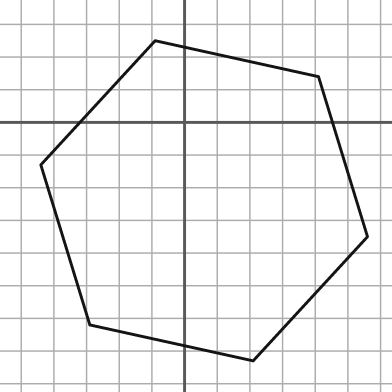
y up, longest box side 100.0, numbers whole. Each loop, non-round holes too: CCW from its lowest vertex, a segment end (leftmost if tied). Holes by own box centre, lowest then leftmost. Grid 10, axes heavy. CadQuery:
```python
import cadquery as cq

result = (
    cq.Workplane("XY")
    .moveTo(21.0, -73.0)
    .lineTo(56.0, -35.0)
    .lineTo(41.0, 14.0)
    .lineTo(-9.0, 25.0)
    .lineTo(-44.0, -13.0)
    .lineTo(-29.0, -62.0)
    .close()
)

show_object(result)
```